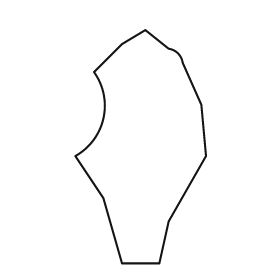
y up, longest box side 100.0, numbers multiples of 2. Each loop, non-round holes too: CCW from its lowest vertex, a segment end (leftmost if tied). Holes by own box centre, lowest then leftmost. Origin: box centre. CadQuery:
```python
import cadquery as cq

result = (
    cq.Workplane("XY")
    .moveTo(-8.0, -50.0)
    .lineTo(8.0, -50.0)
    .lineTo(12.0, -32.0)
    .lineTo(28.0, -4.0)
    .lineTo(26.0, 18.0)
    .lineTo(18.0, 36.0)
    .threePointArc((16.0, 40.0), (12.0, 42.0))
    .lineTo(2.0, 50.0)
    .lineTo(-8.0, 44.0)
    .lineTo(-20.0, 32.0)
    .threePointArc((-16.0, 12.0), (-28.0, -4.0))
    .lineTo(-16.0, -22.0)
    .close()
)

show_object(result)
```